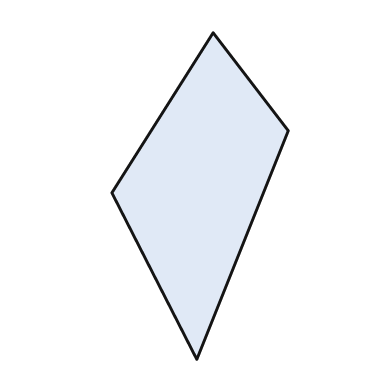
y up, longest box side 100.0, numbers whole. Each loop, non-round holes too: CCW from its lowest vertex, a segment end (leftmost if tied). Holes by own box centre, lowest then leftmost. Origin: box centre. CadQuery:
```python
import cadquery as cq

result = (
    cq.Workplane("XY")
    .moveTo(-1.0, -50.0)
    .lineTo(27.0, 20.0)
    .lineTo(4.0, 50.0)
    .lineTo(-27.0, 1.0)
    .close()
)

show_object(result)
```